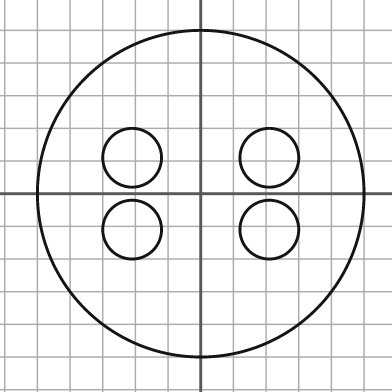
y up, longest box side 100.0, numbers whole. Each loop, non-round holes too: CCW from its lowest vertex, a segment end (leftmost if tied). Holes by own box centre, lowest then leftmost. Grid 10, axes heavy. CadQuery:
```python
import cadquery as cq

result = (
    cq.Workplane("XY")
    .moveTo(0.0, 0.0)
    .circle(50.0)
    .moveTo(-21.0, -11.0)
    .circle(9.0)
    .moveTo(21.0, -11.0)
    .circle(9.0)
    .moveTo(-21.0, 11.0)
    .circle(9.0)
    .moveTo(21.0, 11.0)
    .circle(9.0)
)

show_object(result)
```